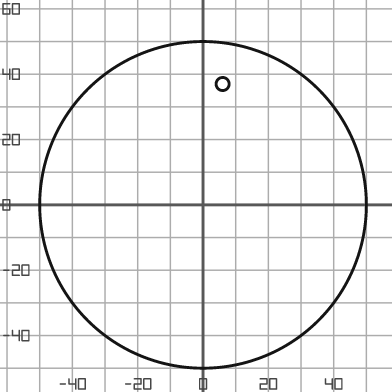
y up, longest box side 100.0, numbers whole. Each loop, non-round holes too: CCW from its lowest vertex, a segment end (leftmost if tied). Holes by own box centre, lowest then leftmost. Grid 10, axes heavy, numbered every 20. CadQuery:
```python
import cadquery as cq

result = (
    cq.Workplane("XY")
    .moveTo(0.0, 0.0)
    .circle(50.0)
    .moveTo(6.0, 37.0)
    .circle(2.0)
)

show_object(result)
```